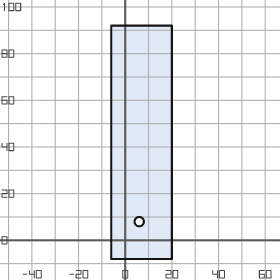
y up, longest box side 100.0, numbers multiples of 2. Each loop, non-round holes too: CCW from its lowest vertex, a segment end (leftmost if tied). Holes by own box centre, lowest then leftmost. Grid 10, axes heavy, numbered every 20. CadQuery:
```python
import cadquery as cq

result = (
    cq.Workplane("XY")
    .moveTo(-6.0, -8.0)
    .lineTo(20.0, -8.0)
    .lineTo(20.0, 92.0)
    .lineTo(-6.0, 92.0)
    .close()
    .moveTo(6.0, 8.0)
    .circle(2.0)
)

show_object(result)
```